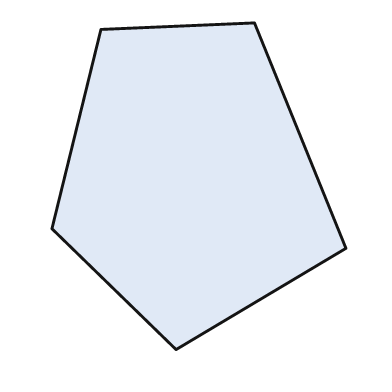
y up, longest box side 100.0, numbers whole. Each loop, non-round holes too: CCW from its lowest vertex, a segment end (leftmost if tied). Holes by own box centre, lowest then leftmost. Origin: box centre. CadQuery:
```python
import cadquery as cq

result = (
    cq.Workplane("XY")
    .moveTo(-7.0, -50.0)
    .lineTo(45.0, -19.0)
    .lineTo(17.0, 50.0)
    .lineTo(-30.0, 48.0)
    .lineTo(-45.0, -13.0)
    .close()
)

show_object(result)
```